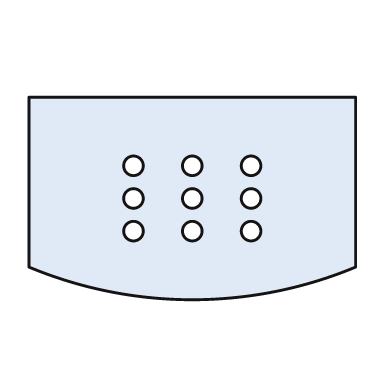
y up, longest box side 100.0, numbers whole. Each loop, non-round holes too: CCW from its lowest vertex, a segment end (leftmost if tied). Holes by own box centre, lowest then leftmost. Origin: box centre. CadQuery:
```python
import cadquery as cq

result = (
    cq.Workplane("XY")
    .moveTo(-50.0, -21.0)
    .threePointArc((0.0, -31.0), (50.0, -21.0))
    .lineTo(50.0, 31.0)
    .lineTo(-50.0, 31.0)
    .close()
    .moveTo(-18.0, -10.0)
    .circle(3.0)
    .moveTo(0.0, -10.0)
    .circle(3.0)
    .moveTo(18.0, -10.0)
    .circle(3.0)
    .moveTo(-18.0, 0.0)
    .circle(3.0)
    .moveTo(0.0, 0.0)
    .circle(3.0)
    .moveTo(18.0, 0.0)
    .circle(3.0)
    .moveTo(-18.0, 10.0)
    .circle(3.0)
    .moveTo(0.0, 10.0)
    .circle(3.0)
    .moveTo(18.0, 10.0)
    .circle(3.0)
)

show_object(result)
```